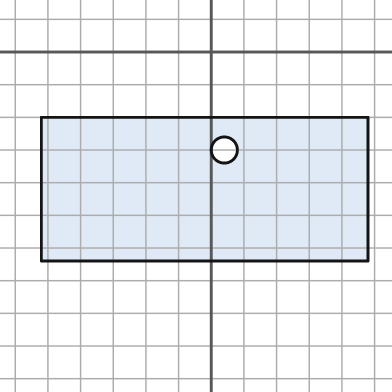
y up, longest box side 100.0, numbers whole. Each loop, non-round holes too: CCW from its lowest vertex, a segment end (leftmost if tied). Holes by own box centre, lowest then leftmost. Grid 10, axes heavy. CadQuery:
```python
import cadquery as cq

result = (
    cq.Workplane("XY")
    .moveTo(-52.0, -64.0)
    .lineTo(48.0, -64.0)
    .lineTo(48.0, -20.0)
    .lineTo(-52.0, -20.0)
    .close()
    .moveTo(4.0, -30.0)
    .circle(4.0)
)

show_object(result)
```